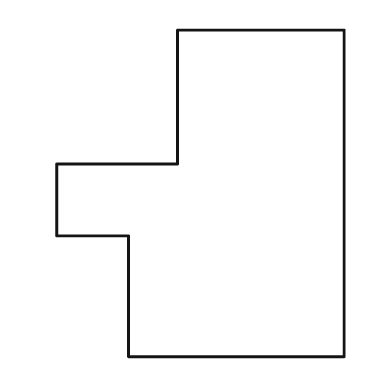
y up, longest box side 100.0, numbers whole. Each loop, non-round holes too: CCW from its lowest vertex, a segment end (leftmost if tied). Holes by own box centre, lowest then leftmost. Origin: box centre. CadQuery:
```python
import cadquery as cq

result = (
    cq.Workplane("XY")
    .moveTo(-22.0, -50.0)
    .lineTo(44.0, -50.0)
    .lineTo(44.0, 50.0)
    .lineTo(-7.0, 50.0)
    .lineTo(-7.0, 9.0)
    .lineTo(-44.0, 9.0)
    .lineTo(-44.0, -13.0)
    .lineTo(-22.0, -13.0)
    .close()
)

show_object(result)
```